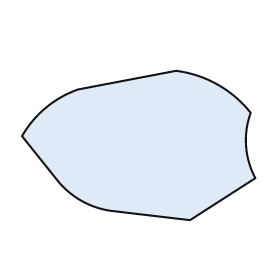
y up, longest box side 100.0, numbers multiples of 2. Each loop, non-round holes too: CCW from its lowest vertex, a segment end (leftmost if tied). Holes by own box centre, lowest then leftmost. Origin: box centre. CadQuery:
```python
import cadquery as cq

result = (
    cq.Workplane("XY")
    .moveTo(22.0, -32.0)
    .lineTo(50.0, -14.0)
    .threePointArc((46.0, 0.0), (48.0, 14.0))
    .threePointArc((34.0, 26.0), (16.0, 32.0))
    .lineTo(-26.0, 24.0)
    .threePointArc((-40.0, 16.0), (-50.0, 4.0))
    .lineTo(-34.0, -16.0)
    .threePointArc((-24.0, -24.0), (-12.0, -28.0))
    .close()
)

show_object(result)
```